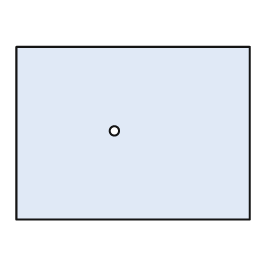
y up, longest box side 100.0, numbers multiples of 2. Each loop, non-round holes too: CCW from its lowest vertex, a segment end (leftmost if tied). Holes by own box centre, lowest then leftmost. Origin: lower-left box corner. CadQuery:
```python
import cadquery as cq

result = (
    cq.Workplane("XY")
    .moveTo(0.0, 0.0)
    .lineTo(100.0, 0.0)
    .lineTo(100.0, 74.0)
    .lineTo(0.0, 74.0)
    .close()
    .moveTo(42.0, 38.0)
    .circle(2.0)
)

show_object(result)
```